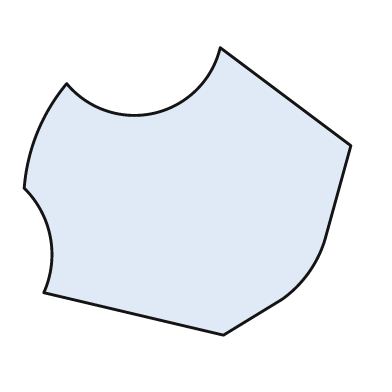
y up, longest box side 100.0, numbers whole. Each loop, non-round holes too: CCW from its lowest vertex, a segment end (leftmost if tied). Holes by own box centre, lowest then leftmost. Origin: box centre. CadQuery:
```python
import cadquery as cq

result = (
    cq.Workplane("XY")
    .moveTo(11.0, -44.0)
    .lineTo(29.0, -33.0)
    .threePointArc((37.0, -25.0), (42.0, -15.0))
    .lineTo(50.0, 14.0)
    .lineTo(10.0, 44.0)
    .threePointArc((-10.0, 24.0), (-37.0, 33.0))
    .threePointArc((-46.0, 18.0), (-50.0, 1.0))
    .threePointArc((-42.0, -14.0), (-44.0, -31.0))
    .close()
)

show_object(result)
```